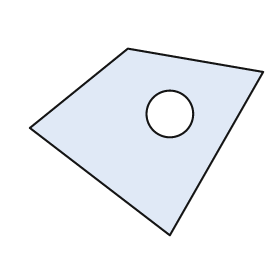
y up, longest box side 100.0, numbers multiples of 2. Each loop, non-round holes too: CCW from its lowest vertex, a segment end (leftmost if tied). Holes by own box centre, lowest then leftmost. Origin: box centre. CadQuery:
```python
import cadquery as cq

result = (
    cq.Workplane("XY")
    .moveTo(10.0, -40.0)
    .lineTo(50.0, 30.0)
    .lineTo(-8.0, 40.0)
    .lineTo(-50.0, 6.0)
    .close()
    .moveTo(10.0, 12.0)
    .circle(10.0)
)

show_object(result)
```